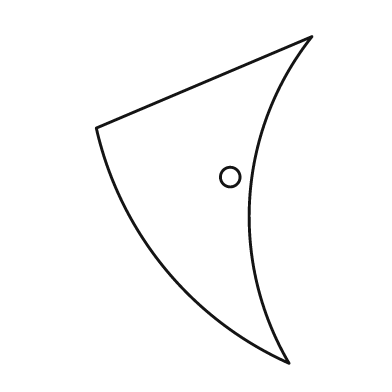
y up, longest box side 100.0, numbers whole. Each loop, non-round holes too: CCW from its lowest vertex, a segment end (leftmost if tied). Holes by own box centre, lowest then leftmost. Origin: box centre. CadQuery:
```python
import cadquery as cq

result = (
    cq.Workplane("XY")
    .moveTo(26.0, -50.0)
    .threePointArc((14.0, 1.0), (33.0, 50.0))
    .lineTo(-33.0, 22.0)
    .threePointArc((-12.0, -21.0), (26.0, -50.0))
    .close()
    .moveTo(8.0, 7.0)
    .circle(3.0)
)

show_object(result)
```